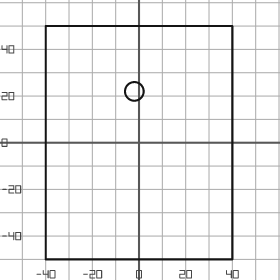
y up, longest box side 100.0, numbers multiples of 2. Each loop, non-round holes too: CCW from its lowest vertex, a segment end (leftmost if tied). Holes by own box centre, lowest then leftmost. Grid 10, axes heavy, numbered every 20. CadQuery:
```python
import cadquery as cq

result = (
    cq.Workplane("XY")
    .moveTo(-40.0, -50.0)
    .lineTo(40.0, -50.0)
    .lineTo(40.0, 50.0)
    .lineTo(-40.0, 50.0)
    .close()
    .moveTo(-2.0, 22.0)
    .circle(4.0)
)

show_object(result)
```